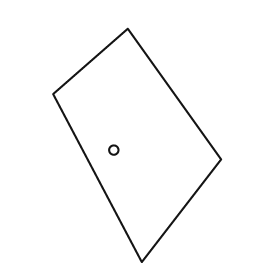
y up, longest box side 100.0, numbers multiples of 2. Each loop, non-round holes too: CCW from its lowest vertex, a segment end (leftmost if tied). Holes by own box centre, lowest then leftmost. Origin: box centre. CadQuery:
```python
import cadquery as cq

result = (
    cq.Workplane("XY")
    .moveTo(2.0, -50.0)
    .lineTo(36.0, -6.0)
    .lineTo(-4.0, 50.0)
    .lineTo(-36.0, 22.0)
    .close()
    .moveTo(-10.0, -2.0)
    .circle(2.0)
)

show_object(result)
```